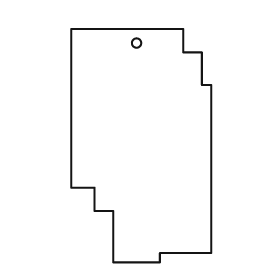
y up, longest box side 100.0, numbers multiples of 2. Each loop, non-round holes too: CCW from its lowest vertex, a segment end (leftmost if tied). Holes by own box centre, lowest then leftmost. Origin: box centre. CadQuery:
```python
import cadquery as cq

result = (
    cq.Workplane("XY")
    .moveTo(-12.0, -50.0)
    .lineTo(8.0, -50.0)
    .lineTo(8.0, -46.0)
    .lineTo(30.0, -46.0)
    .lineTo(30.0, 26.0)
    .lineTo(26.0, 26.0)
    .lineTo(26.0, 40.0)
    .lineTo(18.0, 40.0)
    .lineTo(18.0, 50.0)
    .lineTo(-30.0, 50.0)
    .lineTo(-30.0, -18.0)
    .lineTo(-20.0, -18.0)
    .lineTo(-20.0, -28.0)
    .lineTo(-12.0, -28.0)
    .close()
    .moveTo(-2.0, 44.0)
    .circle(2.0)
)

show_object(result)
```